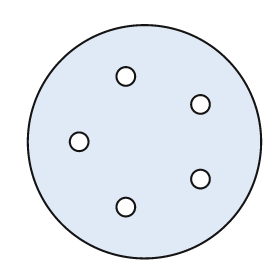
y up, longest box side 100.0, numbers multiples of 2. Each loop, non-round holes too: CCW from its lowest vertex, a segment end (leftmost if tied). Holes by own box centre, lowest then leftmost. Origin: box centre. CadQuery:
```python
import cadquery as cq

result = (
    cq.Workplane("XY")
    .moveTo(0.0, 0.0)
    .circle(50.0)
    .moveTo(-8.0, -28.0)
    .circle(4.0)
    .moveTo(24.0, -16.0)
    .circle(4.0)
    .moveTo(-28.0, 0.0)
    .circle(4.0)
    .moveTo(24.0, 16.0)
    .circle(4.0)
    .moveTo(-8.0, 28.0)
    .circle(4.0)
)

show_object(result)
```